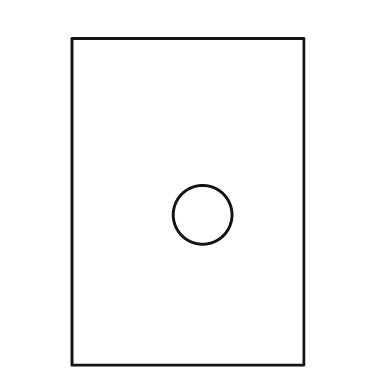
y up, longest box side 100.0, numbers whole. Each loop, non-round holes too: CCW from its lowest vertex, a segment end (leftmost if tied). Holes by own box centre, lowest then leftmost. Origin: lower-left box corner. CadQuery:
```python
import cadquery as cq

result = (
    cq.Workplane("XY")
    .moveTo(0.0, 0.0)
    .lineTo(71.0, 0.0)
    .lineTo(71.0, 100.0)
    .lineTo(0.0, 100.0)
    .close()
    .moveTo(40.0, 46.0)
    .circle(9.0)
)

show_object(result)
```